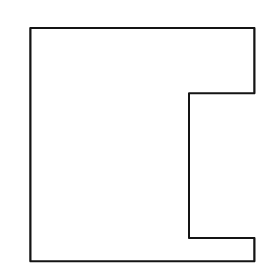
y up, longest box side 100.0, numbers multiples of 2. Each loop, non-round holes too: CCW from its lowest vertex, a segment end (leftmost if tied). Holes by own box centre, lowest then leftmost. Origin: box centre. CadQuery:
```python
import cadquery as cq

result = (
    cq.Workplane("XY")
    .moveTo(-48.0, -50.0)
    .lineTo(48.0, -50.0)
    .lineTo(48.0, -40.0)
    .lineTo(20.0, -40.0)
    .lineTo(20.0, 22.0)
    .lineTo(48.0, 22.0)
    .lineTo(48.0, 50.0)
    .lineTo(-48.0, 50.0)
    .close()
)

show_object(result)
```